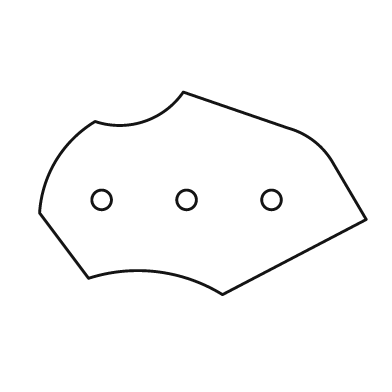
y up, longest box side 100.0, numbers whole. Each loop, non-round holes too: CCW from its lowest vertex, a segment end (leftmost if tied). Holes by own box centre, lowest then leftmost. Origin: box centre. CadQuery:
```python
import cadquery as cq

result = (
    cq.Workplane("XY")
    .moveTo(6.0, -31.0)
    .lineTo(50.0, -8.0)
    .lineTo(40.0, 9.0)
    .threePointArc((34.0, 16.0), (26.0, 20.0))
    .lineTo(-6.0, 31.0)
    .threePointArc((-18.0, 22.0), (-33.0, 22.0))
    .threePointArc((-45.0, 10.0), (-50.0, -6.0))
    .lineTo(-35.0, -26.0)
    .threePointArc((-14.0, -24.0), (6.0, -31.0))
    .close()
    .moveTo(-31.0, -2.0)
    .circle(3.0)
    .moveTo(-5.0, -2.0)
    .circle(3.0)
    .moveTo(21.0, -2.0)
    .circle(3.0)
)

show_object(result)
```